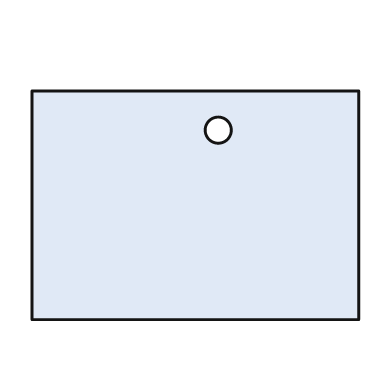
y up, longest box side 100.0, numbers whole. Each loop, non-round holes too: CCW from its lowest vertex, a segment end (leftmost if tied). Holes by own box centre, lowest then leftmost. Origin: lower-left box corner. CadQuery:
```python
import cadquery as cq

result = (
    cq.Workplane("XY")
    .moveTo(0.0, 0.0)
    .lineTo(100.0, 0.0)
    .lineTo(100.0, 70.0)
    .lineTo(0.0, 70.0)
    .close()
    .moveTo(57.0, 58.0)
    .circle(4.0)
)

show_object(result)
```